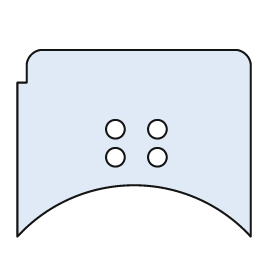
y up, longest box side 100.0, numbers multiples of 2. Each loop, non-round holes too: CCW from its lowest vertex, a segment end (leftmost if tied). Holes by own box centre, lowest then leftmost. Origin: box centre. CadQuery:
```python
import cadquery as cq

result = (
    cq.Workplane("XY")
    .moveTo(-50.0, -40.0)
    .threePointArc((0.0, -18.0), (50.0, -40.0))
    .lineTo(50.0, 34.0)
    .threePointArc((48.0, 38.0), (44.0, 40.0))
    .lineTo(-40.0, 40.0)
    .threePointArc((-44.0, 38.0), (-46.0, 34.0))
    .lineTo(-46.0, 26.0)
    .lineTo(-50.0, 26.0)
    .close()
    .moveTo(-8.0, -6.0)
    .circle(4.0)
    .moveTo(10.0, -6.0)
    .circle(4.0)
    .moveTo(-8.0, 6.0)
    .circle(4.0)
    .moveTo(10.0, 6.0)
    .circle(4.0)
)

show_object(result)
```